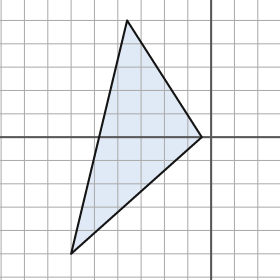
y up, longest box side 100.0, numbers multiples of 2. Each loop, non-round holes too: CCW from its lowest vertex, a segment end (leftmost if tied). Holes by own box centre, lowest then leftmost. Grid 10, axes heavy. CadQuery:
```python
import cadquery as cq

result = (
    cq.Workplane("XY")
    .moveTo(-60.0, -50.0)
    .lineTo(-4.0, 0.0)
    .lineTo(-36.0, 50.0)
    .close()
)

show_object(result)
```